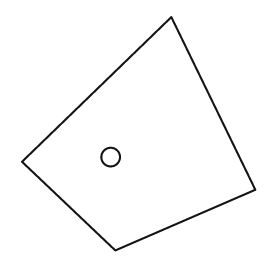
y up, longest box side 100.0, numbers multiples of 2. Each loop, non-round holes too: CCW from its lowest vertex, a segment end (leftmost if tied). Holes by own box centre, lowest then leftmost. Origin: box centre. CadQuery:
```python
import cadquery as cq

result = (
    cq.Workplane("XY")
    .moveTo(-10.0, -50.0)
    .lineTo(50.0, -24.0)
    .lineTo(14.0, 50.0)
    .lineTo(-50.0, -12.0)
    .close()
    .moveTo(-12.0, -10.0)
    .circle(4.0)
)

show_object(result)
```